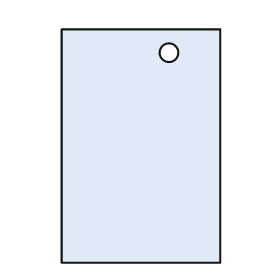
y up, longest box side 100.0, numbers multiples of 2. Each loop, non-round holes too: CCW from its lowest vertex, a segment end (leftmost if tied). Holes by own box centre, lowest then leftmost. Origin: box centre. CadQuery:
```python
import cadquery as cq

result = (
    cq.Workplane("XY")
    .moveTo(-34.0, -50.0)
    .lineTo(34.0, -50.0)
    .lineTo(34.0, 50.0)
    .lineTo(-34.0, 50.0)
    .close()
    .moveTo(12.0, 40.0)
    .circle(4.0)
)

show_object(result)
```